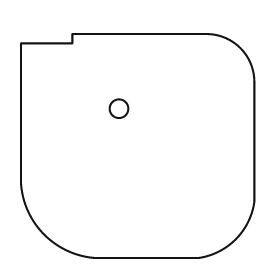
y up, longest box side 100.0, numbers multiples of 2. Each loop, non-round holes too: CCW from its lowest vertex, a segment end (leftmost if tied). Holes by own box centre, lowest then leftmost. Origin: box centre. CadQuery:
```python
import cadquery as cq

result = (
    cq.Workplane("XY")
    .moveTo(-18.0, -48.0)
    .lineTo(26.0, -48.0)
    .threePointArc((42.0, -40.0), (50.0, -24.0))
    .lineTo(50.0, 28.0)
    .threePointArc((44.0, 42.0), (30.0, 48.0))
    .lineTo(-28.0, 48.0)
    .lineTo(-28.0, 44.0)
    .lineTo(-50.0, 44.0)
    .lineTo(-50.0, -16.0)
    .threePointArc((-40.0, -38.0), (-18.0, -48.0))
    .close()
    .moveTo(-8.0, 16.0)
    .circle(4.0)
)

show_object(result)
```